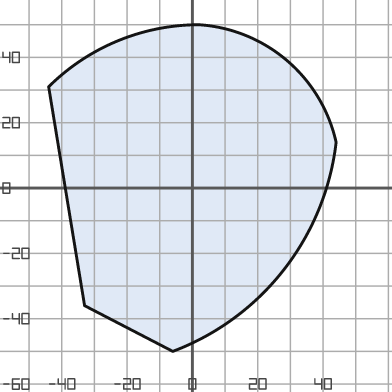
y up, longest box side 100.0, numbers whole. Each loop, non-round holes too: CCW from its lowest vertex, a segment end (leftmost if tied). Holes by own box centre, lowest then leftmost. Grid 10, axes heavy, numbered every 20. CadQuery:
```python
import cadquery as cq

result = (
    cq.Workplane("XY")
    .moveTo(-6.0, -50.0)
    .threePointArc((28.0, -25.0), (44.0, 14.0))
    .threePointArc((29.0, 39.0), (2.0, 50.0))
    .threePointArc((-23.0, 45.0), (-44.0, 31.0))
    .lineTo(-33.0, -36.0)
    .close()
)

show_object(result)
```